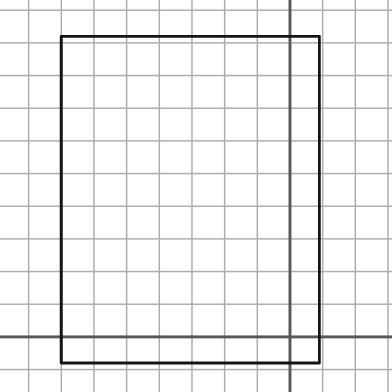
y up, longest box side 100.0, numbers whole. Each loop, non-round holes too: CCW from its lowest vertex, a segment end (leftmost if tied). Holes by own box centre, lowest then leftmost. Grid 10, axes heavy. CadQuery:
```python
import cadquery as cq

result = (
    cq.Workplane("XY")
    .moveTo(-70.0, -8.0)
    .lineTo(9.0, -8.0)
    .lineTo(9.0, 92.0)
    .lineTo(-70.0, 92.0)
    .close()
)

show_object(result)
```